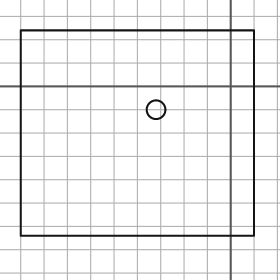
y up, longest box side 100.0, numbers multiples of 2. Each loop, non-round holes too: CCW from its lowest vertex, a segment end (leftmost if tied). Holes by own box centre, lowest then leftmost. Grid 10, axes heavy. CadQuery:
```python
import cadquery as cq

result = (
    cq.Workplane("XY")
    .moveTo(-90.0, -64.0)
    .lineTo(10.0, -64.0)
    .lineTo(10.0, 24.0)
    .lineTo(-90.0, 24.0)
    .close()
    .moveTo(-32.0, -10.0)
    .circle(4.0)
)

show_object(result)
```